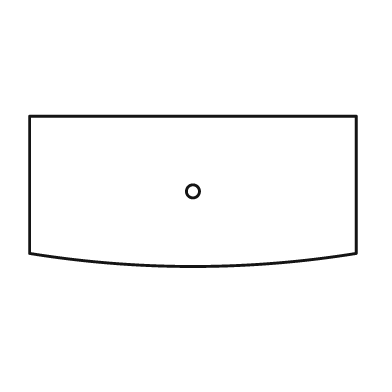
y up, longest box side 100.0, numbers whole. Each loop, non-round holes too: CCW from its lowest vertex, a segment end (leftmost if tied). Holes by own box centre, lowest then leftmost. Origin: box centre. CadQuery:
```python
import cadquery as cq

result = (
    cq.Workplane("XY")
    .moveTo(-50.0, -19.0)
    .threePointArc((0.0, -23.0), (50.0, -19.0))
    .lineTo(50.0, 23.0)
    .lineTo(-50.0, 23.0)
    .close()
    .moveTo(0.0, 0.0)
    .circle(2.0)
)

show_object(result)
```